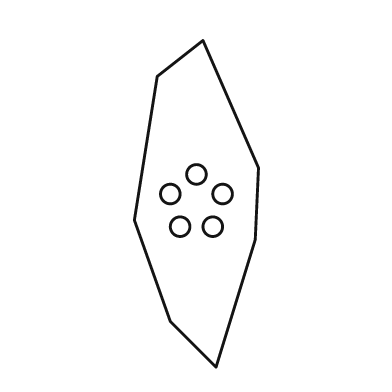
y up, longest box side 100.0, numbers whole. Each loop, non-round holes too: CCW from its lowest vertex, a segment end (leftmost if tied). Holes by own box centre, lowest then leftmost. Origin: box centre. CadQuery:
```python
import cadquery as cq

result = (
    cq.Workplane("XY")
    .moveTo(6.0, -50.0)
    .lineTo(18.0, -11.0)
    .lineTo(19.0, 11.0)
    .lineTo(2.0, 50.0)
    .lineTo(-12.0, 39.0)
    .lineTo(-19.0, -5.0)
    .lineTo(-8.0, -36.0)
    .close()
    .moveTo(-5.0, -7.0)
    .circle(3.0)
    .moveTo(5.0, -7.0)
    .circle(3.0)
    .moveTo(-8.0, 3.0)
    .circle(3.0)
    .moveTo(8.0, 3.0)
    .circle(3.0)
    .moveTo(0.0, 9.0)
    .circle(3.0)
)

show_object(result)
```